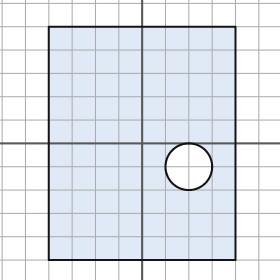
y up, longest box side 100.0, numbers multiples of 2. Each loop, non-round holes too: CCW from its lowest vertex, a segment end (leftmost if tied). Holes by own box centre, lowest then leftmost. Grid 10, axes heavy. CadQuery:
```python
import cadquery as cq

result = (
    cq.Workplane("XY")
    .moveTo(-40.0, -50.0)
    .lineTo(40.0, -50.0)
    .lineTo(40.0, 50.0)
    .lineTo(-40.0, 50.0)
    .close()
    .moveTo(20.0, -10.0)
    .circle(10.0)
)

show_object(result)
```